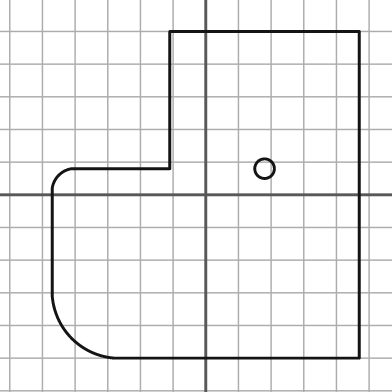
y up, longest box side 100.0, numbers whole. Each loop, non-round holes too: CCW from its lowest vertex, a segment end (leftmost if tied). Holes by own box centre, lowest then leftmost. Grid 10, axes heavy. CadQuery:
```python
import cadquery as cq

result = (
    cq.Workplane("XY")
    .moveTo(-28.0, -50.0)
    .lineTo(47.0, -50.0)
    .lineTo(47.0, 50.0)
    .lineTo(-11.0, 50.0)
    .lineTo(-11.0, 8.0)
    .lineTo(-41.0, 8.0)
    .threePointArc((-45.0, 6.0), (-47.0, 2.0))
    .lineTo(-47.0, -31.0)
    .threePointArc((-41.0, -44.0), (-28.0, -50.0))
    .close()
    .moveTo(18.0, 8.0)
    .circle(3.0)
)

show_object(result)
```